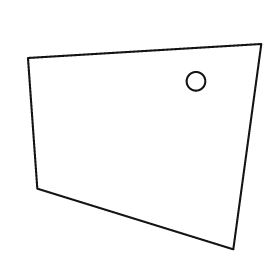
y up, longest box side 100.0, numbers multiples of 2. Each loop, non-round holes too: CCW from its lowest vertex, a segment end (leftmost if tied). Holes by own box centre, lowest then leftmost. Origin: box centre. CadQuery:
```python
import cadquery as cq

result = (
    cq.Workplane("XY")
    .moveTo(38.0, -44.0)
    .lineTo(50.0, 44.0)
    .lineTo(-50.0, 38.0)
    .lineTo(-46.0, -18.0)
    .close()
    .moveTo(22.0, 28.0)
    .circle(4.0)
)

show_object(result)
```